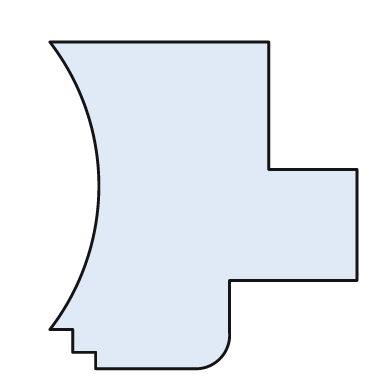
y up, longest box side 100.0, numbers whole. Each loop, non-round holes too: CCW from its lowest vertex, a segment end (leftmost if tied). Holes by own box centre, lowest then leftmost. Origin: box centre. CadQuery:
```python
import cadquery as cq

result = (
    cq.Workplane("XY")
    .moveTo(-33.0, -50.0)
    .lineTo(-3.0, -50.0)
    .threePointArc((5.0, -47.0), (8.0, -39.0))
    .lineTo(8.0, -23.0)
    .lineTo(47.0, -23.0)
    .lineTo(47.0, 11.0)
    .lineTo(20.0, 11.0)
    .lineTo(20.0, 50.0)
    .lineTo(-47.0, 50.0)
    .threePointArc((-32.0, 6.0), (-47.0, -38.0))
    .lineTo(-40.0, -38.0)
    .lineTo(-40.0, -45.0)
    .lineTo(-33.0, -45.0)
    .close()
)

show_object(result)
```